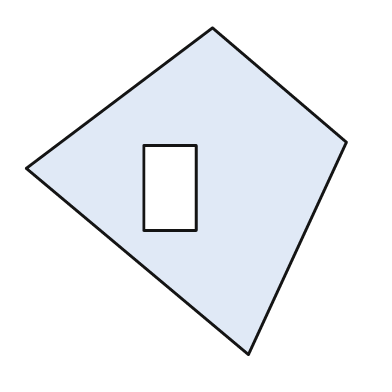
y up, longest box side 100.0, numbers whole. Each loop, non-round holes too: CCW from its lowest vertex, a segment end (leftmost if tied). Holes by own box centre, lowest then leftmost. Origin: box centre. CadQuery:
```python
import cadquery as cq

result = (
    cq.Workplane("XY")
    .moveTo(19.0, -50.0)
    .lineTo(49.0, 15.0)
    .lineTo(8.0, 50.0)
    .lineTo(-49.0, 7.0)
    .close()
    .moveTo(-13.0, -12.0)
    .lineTo(3.0, -12.0)
    .lineTo(3.0, 14.0)
    .lineTo(-13.0, 14.0)
    .close()
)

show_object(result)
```